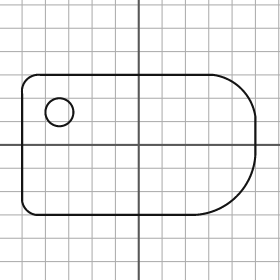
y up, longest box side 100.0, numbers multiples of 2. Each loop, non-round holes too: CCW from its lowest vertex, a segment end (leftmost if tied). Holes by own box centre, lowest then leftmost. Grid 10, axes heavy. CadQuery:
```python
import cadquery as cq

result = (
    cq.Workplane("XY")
    .moveTo(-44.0, -30.0)
    .lineTo(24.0, -30.0)
    .threePointArc((42.0, -22.0), (50.0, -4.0))
    .lineTo(50.0, 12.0)
    .threePointArc((44.0, 24.0), (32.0, 30.0))
    .lineTo(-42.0, 30.0)
    .threePointArc((-48.0, 28.0), (-50.0, 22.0))
    .lineTo(-50.0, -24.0)
    .threePointArc((-48.0, -28.0), (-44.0, -30.0))
    .close()
    .moveTo(-34.0, 14.0)
    .circle(6.0)
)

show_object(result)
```